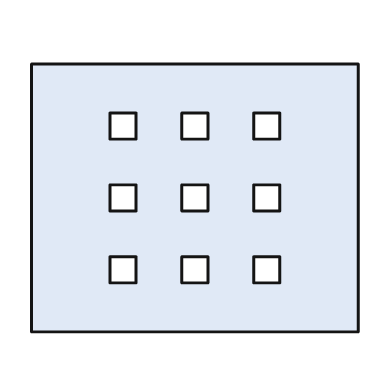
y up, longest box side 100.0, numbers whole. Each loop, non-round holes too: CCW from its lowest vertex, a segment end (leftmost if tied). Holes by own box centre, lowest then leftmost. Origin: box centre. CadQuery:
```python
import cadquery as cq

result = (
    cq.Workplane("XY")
    .moveTo(-50.0, -41.0)
    .lineTo(50.0, -41.0)
    .lineTo(50.0, 41.0)
    .lineTo(-50.0, 41.0)
    .close()
    .moveTo(-26.0, -26.0)
    .lineTo(-18.0, -26.0)
    .lineTo(-18.0, -18.0)
    .lineTo(-26.0, -18.0)
    .close()
    .moveTo(-4.0, -26.0)
    .lineTo(4.0, -26.0)
    .lineTo(4.0, -18.0)
    .lineTo(-4.0, -18.0)
    .close()
    .moveTo(18.0, -26.0)
    .lineTo(26.0, -26.0)
    .lineTo(26.0, -18.0)
    .lineTo(18.0, -18.0)
    .close()
    .moveTo(-26.0, -4.0)
    .lineTo(-18.0, -4.0)
    .lineTo(-18.0, 4.0)
    .lineTo(-26.0, 4.0)
    .close()
    .moveTo(-4.0, -4.0)
    .lineTo(4.0, -4.0)
    .lineTo(4.0, 4.0)
    .lineTo(-4.0, 4.0)
    .close()
    .moveTo(18.0, -4.0)
    .lineTo(26.0, -4.0)
    .lineTo(26.0, 4.0)
    .lineTo(18.0, 4.0)
    .close()
    .moveTo(-26.0, 18.0)
    .lineTo(-18.0, 18.0)
    .lineTo(-18.0, 26.0)
    .lineTo(-26.0, 26.0)
    .close()
    .moveTo(-4.0, 18.0)
    .lineTo(4.0, 18.0)
    .lineTo(4.0, 26.0)
    .lineTo(-4.0, 26.0)
    .close()
    .moveTo(18.0, 18.0)
    .lineTo(26.0, 18.0)
    .lineTo(26.0, 26.0)
    .lineTo(18.0, 26.0)
    .close()
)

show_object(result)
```